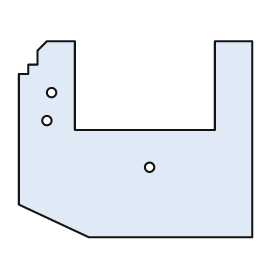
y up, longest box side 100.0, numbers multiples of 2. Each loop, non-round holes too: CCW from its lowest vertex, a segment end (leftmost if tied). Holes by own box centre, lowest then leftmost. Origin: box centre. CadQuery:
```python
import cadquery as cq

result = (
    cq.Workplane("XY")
    .moveTo(-20.0, -42.0)
    .lineTo(50.0, -42.0)
    .lineTo(50.0, 42.0)
    .lineTo(34.0, 42.0)
    .lineTo(34.0, 4.0)
    .lineTo(-26.0, 4.0)
    .lineTo(-26.0, 42.0)
    .lineTo(-38.0, 42.0)
    .lineTo(-42.0, 38.0)
    .lineTo(-42.0, 32.0)
    .lineTo(-46.0, 32.0)
    .lineTo(-46.0, 28.0)
    .lineTo(-50.0, 28.0)
    .lineTo(-50.0, -28.0)
    .close()
    .moveTo(6.0, -12.0)
    .circle(2.0)
    .moveTo(-38.0, 8.0)
    .circle(2.0)
    .moveTo(-36.0, 20.0)
    .circle(2.0)
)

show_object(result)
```